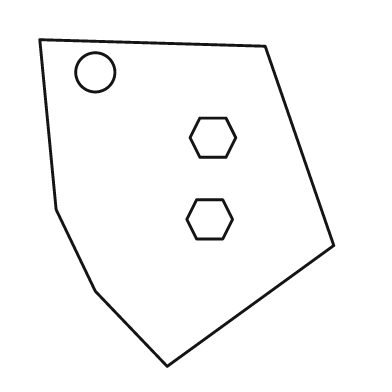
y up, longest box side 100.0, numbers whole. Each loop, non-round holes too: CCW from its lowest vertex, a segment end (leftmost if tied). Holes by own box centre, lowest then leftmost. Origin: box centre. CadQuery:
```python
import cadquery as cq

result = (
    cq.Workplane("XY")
    .moveTo(-6.0, -50.0)
    .lineTo(45.0, -13.0)
    .lineTo(24.0, 48.0)
    .lineTo(-45.0, 50.0)
    .lineTo(-40.0, -2.0)
    .lineTo(-28.0, -27.0)
    .close()
    .moveTo(3.0, -11.0)
    .lineTo(11.0, -11.0)
    .lineTo(14.0, -5.0)
    .lineTo(11.0, 1.0)
    .lineTo(3.0, 1.0)
    .lineTo(0.0, -5.0)
    .close()
    .moveTo(4.0, 14.0)
    .lineTo(12.0, 14.0)
    .lineTo(15.0, 20.0)
    .lineTo(12.0, 26.0)
    .lineTo(4.0, 26.0)
    .lineTo(1.0, 20.0)
    .close()
    .moveTo(-28.0, 40.0)
    .circle(6.0)
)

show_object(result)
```